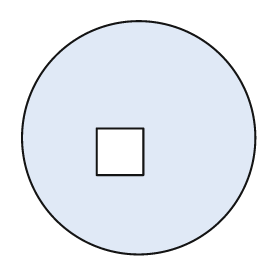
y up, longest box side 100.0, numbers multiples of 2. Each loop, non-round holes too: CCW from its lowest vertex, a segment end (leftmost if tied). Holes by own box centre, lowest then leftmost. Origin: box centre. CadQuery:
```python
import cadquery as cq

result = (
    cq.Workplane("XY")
    .moveTo(0.0, 0.0)
    .circle(50.0)
    .moveTo(-18.0, -16.0)
    .lineTo(2.0, -16.0)
    .lineTo(2.0, 4.0)
    .lineTo(-18.0, 4.0)
    .close()
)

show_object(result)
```